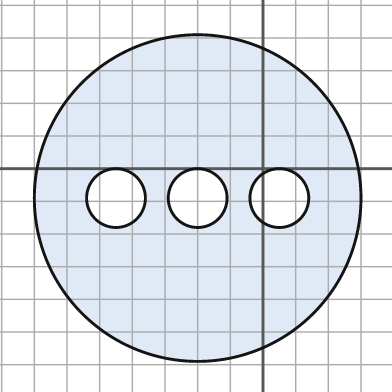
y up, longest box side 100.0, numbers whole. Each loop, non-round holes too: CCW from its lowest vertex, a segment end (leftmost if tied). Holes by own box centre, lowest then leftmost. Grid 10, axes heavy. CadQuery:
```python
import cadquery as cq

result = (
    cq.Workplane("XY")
    .moveTo(-20.0, -9.0)
    .circle(50.0)
    .moveTo(-45.0, -9.0)
    .circle(9.0)
    .moveTo(-20.0, -9.0)
    .circle(9.0)
    .moveTo(5.0, -9.0)
    .circle(9.0)
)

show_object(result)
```